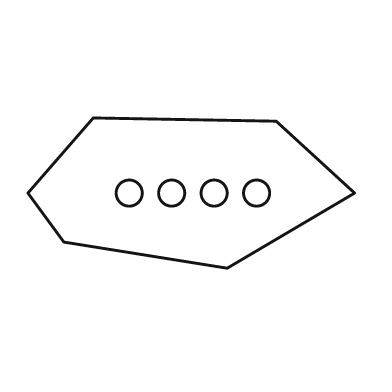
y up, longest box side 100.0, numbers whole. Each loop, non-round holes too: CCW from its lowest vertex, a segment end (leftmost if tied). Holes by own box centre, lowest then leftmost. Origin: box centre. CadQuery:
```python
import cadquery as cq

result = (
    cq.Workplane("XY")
    .moveTo(11.0, -23.0)
    .lineTo(50.0, 0.0)
    .lineTo(26.0, 22.0)
    .lineTo(-30.0, 23.0)
    .lineTo(-50.0, 0.0)
    .lineTo(-39.0, -15.0)
    .close()
    .moveTo(-19.0, 0.0)
    .circle(4.0)
    .moveTo(-6.0, 0.0)
    .circle(4.0)
    .moveTo(7.0, 0.0)
    .circle(4.0)
    .moveTo(20.0, 0.0)
    .circle(4.0)
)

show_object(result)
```